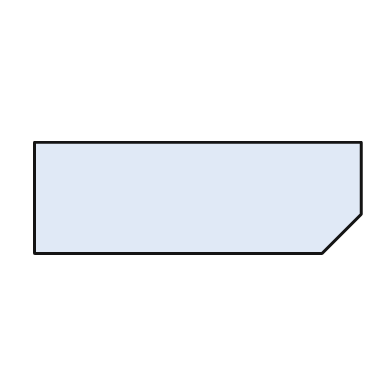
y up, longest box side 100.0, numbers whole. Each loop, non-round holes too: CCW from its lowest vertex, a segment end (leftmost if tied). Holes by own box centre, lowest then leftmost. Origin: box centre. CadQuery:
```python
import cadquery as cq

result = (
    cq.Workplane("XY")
    .moveTo(-50.0, -17.0)
    .lineTo(38.0, -17.0)
    .lineTo(50.0, -5.0)
    .lineTo(50.0, 17.0)
    .lineTo(-50.0, 17.0)
    .close()
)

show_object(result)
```